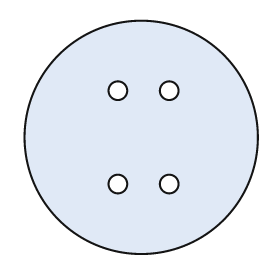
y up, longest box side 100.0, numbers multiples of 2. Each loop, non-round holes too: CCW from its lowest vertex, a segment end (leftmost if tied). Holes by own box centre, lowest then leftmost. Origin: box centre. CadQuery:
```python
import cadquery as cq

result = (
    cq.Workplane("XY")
    .moveTo(0.0, 0.0)
    .circle(50.0)
    .moveTo(-10.0, -20.0)
    .circle(4.0)
    .moveTo(12.0, -20.0)
    .circle(4.0)
    .moveTo(-10.0, 20.0)
    .circle(4.0)
    .moveTo(12.0, 20.0)
    .circle(4.0)
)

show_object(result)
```